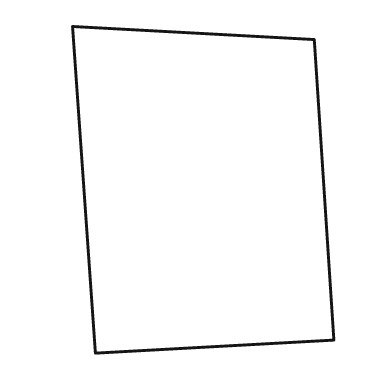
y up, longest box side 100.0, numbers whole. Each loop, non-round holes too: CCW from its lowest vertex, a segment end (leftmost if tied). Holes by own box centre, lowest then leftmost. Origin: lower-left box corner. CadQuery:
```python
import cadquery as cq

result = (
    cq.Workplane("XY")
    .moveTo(7.0, 0.0)
    .lineTo(80.0, 4.0)
    .lineTo(74.0, 96.0)
    .lineTo(0.0, 100.0)
    .close()
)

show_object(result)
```